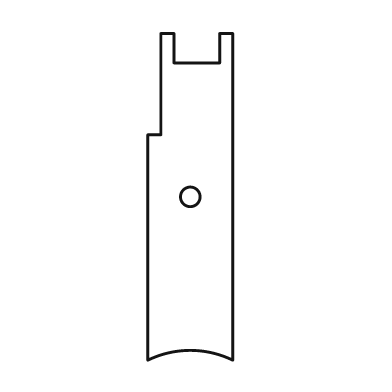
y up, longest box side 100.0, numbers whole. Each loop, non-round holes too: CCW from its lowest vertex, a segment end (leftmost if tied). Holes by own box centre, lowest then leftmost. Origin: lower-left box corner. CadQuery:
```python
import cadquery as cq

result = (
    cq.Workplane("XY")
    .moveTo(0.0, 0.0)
    .threePointArc((13.0, 3.0), (26.0, 0.0))
    .lineTo(26.0, 100.0)
    .lineTo(22.0, 100.0)
    .lineTo(22.0, 91.0)
    .lineTo(8.0, 91.0)
    .lineTo(8.0, 100.0)
    .lineTo(4.0, 100.0)
    .lineTo(4.0, 69.0)
    .lineTo(0.0, 69.0)
    .close()
    .moveTo(13.0, 50.0)
    .circle(3.0)
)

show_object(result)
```